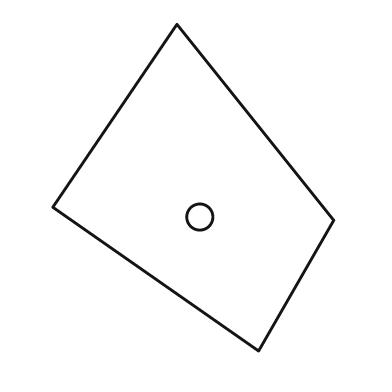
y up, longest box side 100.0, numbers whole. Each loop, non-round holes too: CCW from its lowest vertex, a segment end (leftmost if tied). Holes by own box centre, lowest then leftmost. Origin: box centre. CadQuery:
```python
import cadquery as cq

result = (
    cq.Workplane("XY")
    .moveTo(20.0, -50.0)
    .lineTo(43.0, -10.0)
    .lineTo(-5.0, 50.0)
    .lineTo(-43.0, -6.0)
    .close()
    .moveTo(2.0, -9.0)
    .circle(4.0)
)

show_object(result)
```